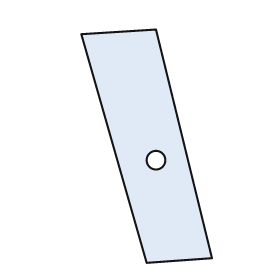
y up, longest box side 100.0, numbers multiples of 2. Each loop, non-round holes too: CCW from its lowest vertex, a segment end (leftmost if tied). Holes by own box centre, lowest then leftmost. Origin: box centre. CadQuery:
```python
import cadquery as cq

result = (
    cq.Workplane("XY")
    .moveTo(0.0, -50.0)
    .lineTo(28.0, -48.0)
    .lineTo(4.0, 50.0)
    .lineTo(-28.0, 48.0)
    .close()
    .moveTo(4.0, -6.0)
    .circle(4.0)
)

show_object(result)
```